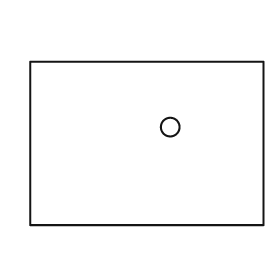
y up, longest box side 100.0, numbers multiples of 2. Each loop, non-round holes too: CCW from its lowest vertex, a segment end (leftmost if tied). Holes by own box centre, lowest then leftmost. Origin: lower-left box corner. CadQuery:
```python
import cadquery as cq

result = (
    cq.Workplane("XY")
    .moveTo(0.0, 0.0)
    .lineTo(100.0, 0.0)
    .lineTo(100.0, 70.0)
    .lineTo(0.0, 70.0)
    .close()
    .moveTo(60.0, 42.0)
    .circle(4.0)
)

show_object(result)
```